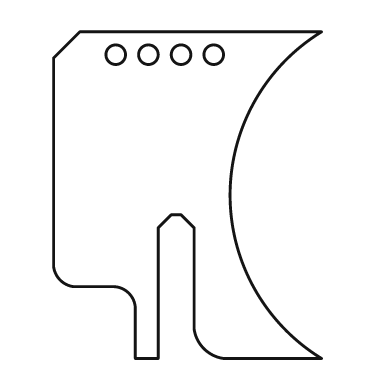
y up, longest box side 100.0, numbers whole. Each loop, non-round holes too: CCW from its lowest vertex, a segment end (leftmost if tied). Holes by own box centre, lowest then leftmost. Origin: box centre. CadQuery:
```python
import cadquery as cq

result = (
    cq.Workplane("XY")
    .moveTo(-16.0, -50.0)
    .lineTo(-9.0, -50.0)
    .lineTo(-9.0, -10.0)
    .lineTo(-5.0, -6.0)
    .lineTo(-2.0, -6.0)
    .lineTo(2.0, -10.0)
    .lineTo(2.0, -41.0)
    .threePointArc((5.0, -47.0), (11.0, -50.0))
    .lineTo(41.0, -50.0)
    .threePointArc((13.0, 0.0), (41.0, 50.0))
    .lineTo(-33.0, 50.0)
    .lineTo(-41.0, 42.0)
    .lineTo(-41.0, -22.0)
    .threePointArc((-39.0, -26.0), (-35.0, -28.0))
    .lineTo(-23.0, -28.0)
    .threePointArc((-18.0, -30.0), (-16.0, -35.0))
    .close()
    .moveTo(-22.0, 43.0)
    .circle(3.0)
    .moveTo(-12.0, 43.0)
    .circle(3.0)
    .moveTo(-2.0, 43.0)
    .circle(3.0)
    .moveTo(8.0, 43.0)
    .circle(3.0)
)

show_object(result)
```